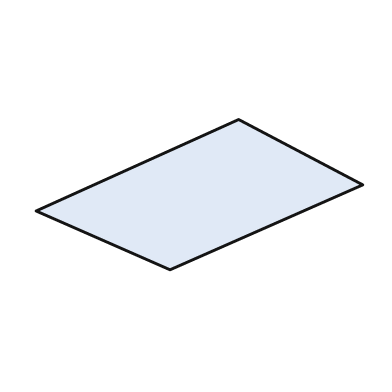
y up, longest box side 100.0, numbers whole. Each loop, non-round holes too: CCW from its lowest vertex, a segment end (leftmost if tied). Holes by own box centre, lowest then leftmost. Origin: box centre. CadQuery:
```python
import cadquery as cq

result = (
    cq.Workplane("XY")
    .moveTo(-9.0, -23.0)
    .lineTo(50.0, 3.0)
    .lineTo(12.0, 23.0)
    .lineTo(-50.0, -5.0)
    .close()
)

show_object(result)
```